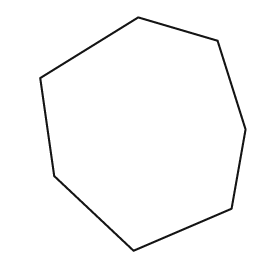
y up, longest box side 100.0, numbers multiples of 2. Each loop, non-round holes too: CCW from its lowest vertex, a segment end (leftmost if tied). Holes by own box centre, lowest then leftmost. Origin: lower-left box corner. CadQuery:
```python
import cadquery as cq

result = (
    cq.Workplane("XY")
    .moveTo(40.0, 0.0)
    .lineTo(82.0, 18.0)
    .lineTo(88.0, 52.0)
    .lineTo(76.0, 90.0)
    .lineTo(42.0, 100.0)
    .lineTo(0.0, 74.0)
    .lineTo(6.0, 32.0)
    .close()
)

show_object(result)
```